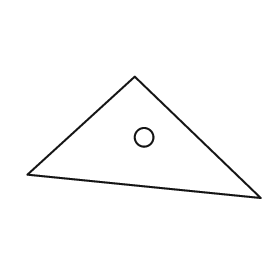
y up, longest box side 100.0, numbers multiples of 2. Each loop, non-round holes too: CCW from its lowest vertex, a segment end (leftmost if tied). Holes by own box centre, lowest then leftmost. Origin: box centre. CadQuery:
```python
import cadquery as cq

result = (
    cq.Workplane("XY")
    .moveTo(50.0, -26.0)
    .lineTo(-4.0, 26.0)
    .lineTo(-50.0, -16.0)
    .close()
    .moveTo(0.0, 0.0)
    .circle(4.0)
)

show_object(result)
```